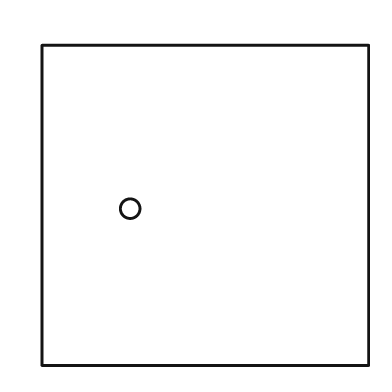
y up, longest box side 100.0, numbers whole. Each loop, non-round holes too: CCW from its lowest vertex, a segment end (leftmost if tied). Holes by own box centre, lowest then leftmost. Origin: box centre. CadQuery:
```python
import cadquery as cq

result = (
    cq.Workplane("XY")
    .moveTo(-50.0, -49.0)
    .lineTo(50.0, -49.0)
    .lineTo(50.0, 49.0)
    .lineTo(-50.0, 49.0)
    .close()
    .moveTo(-23.0, -1.0)
    .circle(3.0)
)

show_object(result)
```